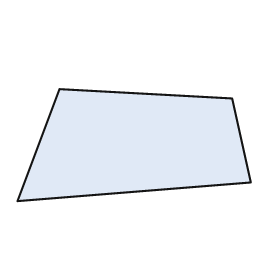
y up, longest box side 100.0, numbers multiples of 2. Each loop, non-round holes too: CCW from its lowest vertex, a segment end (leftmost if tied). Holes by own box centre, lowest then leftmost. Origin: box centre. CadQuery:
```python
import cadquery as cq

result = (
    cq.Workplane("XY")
    .moveTo(-50.0, -24.0)
    .lineTo(50.0, -16.0)
    .lineTo(42.0, 20.0)
    .lineTo(-32.0, 24.0)
    .close()
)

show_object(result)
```